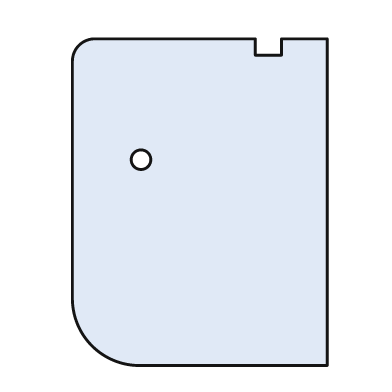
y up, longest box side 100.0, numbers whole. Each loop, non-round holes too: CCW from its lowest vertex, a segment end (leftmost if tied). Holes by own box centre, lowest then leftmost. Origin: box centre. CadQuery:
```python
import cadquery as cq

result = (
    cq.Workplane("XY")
    .moveTo(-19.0, -50.0)
    .lineTo(39.0, -50.0)
    .lineTo(39.0, 50.0)
    .lineTo(25.0, 50.0)
    .lineTo(25.0, 45.0)
    .lineTo(17.0, 45.0)
    .lineTo(17.0, 50.0)
    .lineTo(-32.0, 50.0)
    .threePointArc((-37.0, 48.0), (-39.0, 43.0))
    .lineTo(-39.0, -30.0)
    .threePointArc((-33.0, -44.0), (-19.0, -50.0))
    .close()
    .moveTo(-18.0, 13.0)
    .circle(3.0)
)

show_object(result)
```